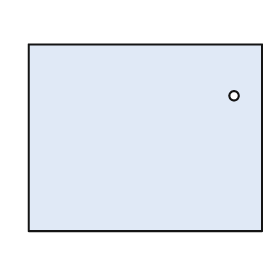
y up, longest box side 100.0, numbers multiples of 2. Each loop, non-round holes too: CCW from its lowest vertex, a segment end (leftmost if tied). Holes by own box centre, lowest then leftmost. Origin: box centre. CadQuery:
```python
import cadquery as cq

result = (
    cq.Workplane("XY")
    .moveTo(-50.0, -40.0)
    .lineTo(50.0, -40.0)
    .lineTo(50.0, 40.0)
    .lineTo(-50.0, 40.0)
    .close()
    .moveTo(38.0, 18.0)
    .circle(2.0)
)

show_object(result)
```